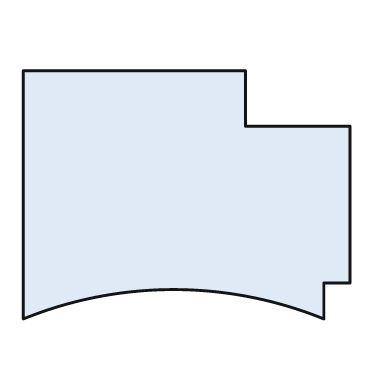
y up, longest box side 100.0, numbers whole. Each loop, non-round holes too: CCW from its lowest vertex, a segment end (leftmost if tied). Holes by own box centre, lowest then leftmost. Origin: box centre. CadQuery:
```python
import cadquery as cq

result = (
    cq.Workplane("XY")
    .moveTo(-50.0, -38.0)
    .threePointArc((-4.0, -29.0), (42.0, -38.0))
    .lineTo(42.0, -27.0)
    .lineTo(50.0, -27.0)
    .lineTo(50.0, 21.0)
    .lineTo(18.0, 21.0)
    .lineTo(18.0, 38.0)
    .lineTo(-50.0, 38.0)
    .close()
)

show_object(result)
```